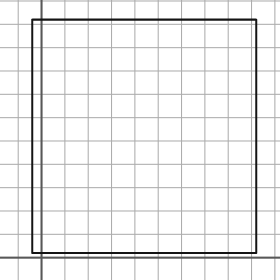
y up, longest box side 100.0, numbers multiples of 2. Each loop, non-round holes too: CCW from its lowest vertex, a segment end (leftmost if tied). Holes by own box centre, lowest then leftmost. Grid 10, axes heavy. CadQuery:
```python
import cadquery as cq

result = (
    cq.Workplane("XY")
    .moveTo(-4.0, 2.0)
    .lineTo(92.0, 2.0)
    .lineTo(92.0, 102.0)
    .lineTo(-4.0, 102.0)
    .close()
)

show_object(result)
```